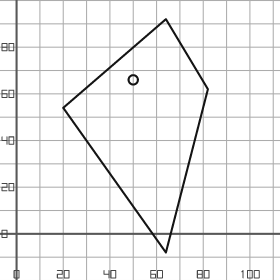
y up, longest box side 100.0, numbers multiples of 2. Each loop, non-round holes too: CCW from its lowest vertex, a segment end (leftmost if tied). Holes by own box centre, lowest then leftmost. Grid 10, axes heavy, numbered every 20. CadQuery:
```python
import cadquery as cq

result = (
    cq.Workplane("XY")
    .moveTo(64.0, -8.0)
    .lineTo(82.0, 62.0)
    .lineTo(64.0, 92.0)
    .lineTo(20.0, 54.0)
    .close()
    .moveTo(50.0, 66.0)
    .circle(2.0)
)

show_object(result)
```